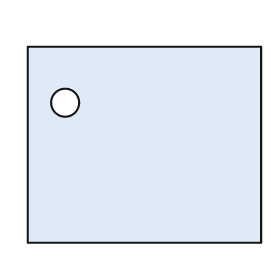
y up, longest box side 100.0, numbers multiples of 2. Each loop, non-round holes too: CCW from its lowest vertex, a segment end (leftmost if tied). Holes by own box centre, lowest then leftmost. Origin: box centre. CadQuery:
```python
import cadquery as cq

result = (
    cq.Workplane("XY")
    .moveTo(-50.0, -42.0)
    .lineTo(50.0, -42.0)
    .lineTo(50.0, 42.0)
    .lineTo(-50.0, 42.0)
    .close()
    .moveTo(-34.0, 18.0)
    .circle(6.0)
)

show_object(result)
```